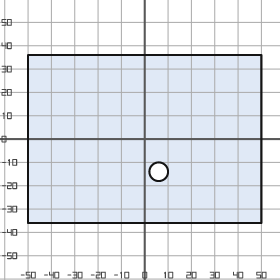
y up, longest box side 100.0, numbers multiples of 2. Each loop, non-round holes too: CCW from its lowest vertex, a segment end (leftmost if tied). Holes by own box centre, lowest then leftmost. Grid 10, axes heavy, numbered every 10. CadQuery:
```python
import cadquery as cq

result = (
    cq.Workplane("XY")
    .moveTo(-50.0, -36.0)
    .lineTo(50.0, -36.0)
    .lineTo(50.0, 36.0)
    .lineTo(-50.0, 36.0)
    .close()
    .moveTo(6.0, -14.0)
    .circle(4.0)
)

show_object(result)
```